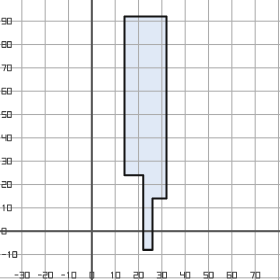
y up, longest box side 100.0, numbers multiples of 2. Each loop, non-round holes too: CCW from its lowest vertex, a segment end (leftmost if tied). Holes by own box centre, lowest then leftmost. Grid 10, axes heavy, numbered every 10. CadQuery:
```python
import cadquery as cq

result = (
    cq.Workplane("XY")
    .moveTo(22.0, -8.0)
    .lineTo(26.0, -8.0)
    .lineTo(26.0, 14.0)
    .lineTo(32.0, 14.0)
    .lineTo(32.0, 92.0)
    .lineTo(14.0, 92.0)
    .lineTo(14.0, 24.0)
    .lineTo(22.0, 24.0)
    .close()
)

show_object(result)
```